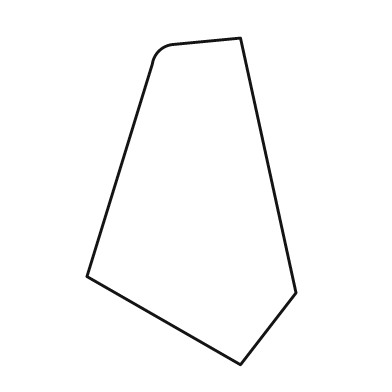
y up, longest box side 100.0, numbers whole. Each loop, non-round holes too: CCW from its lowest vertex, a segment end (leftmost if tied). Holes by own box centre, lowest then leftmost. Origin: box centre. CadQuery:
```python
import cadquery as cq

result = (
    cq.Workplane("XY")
    .moveTo(15.0, -50.0)
    .lineTo(32.0, -28.0)
    .lineTo(15.0, 50.0)
    .lineTo(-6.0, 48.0)
    .threePointArc((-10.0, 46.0), (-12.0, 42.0))
    .lineTo(-32.0, -23.0)
    .close()
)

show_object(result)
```